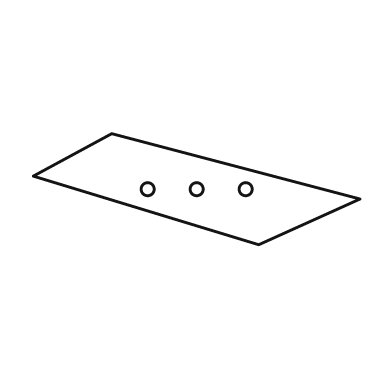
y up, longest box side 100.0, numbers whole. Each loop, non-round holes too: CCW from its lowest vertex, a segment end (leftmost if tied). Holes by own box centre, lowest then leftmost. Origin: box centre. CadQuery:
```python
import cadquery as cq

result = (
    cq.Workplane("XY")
    .moveTo(19.0, -17.0)
    .lineTo(50.0, -3.0)
    .lineTo(-26.0, 17.0)
    .lineTo(-50.0, 4.0)
    .close()
    .moveTo(-15.0, 0.0)
    .circle(2.0)
    .moveTo(0.0, 0.0)
    .circle(2.0)
    .moveTo(15.0, 0.0)
    .circle(2.0)
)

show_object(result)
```